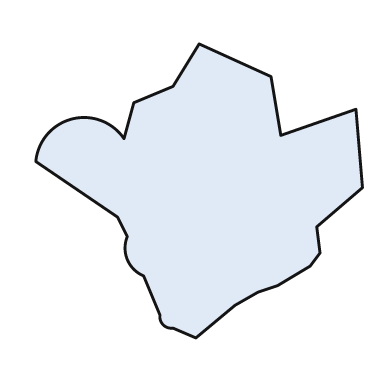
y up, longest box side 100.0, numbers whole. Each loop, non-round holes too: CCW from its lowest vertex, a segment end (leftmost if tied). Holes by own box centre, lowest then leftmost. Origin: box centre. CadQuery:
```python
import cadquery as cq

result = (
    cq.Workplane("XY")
    .moveTo(-1.0, -45.0)
    .lineTo(11.0, -35.0)
    .lineTo(18.0, -31.0)
    .lineTo(24.0, -29.0)
    .lineTo(34.0, -23.0)
    .lineTo(37.0, -19.0)
    .lineTo(36.0, -11.0)
    .lineTo(50.0, 1.0)
    .lineTo(48.0, 25.0)
    .lineTo(25.0, 17.0)
    .lineTo(22.0, 35.0)
    .lineTo(0.0, 45.0)
    .lineTo(-8.0, 32.0)
    .lineTo(-20.0, 27.0)
    .lineTo(-23.0, 16.0)
    .threePointArc((-39.0, 22.0), (-50.0, 9.0))
    .lineTo(-25.0, -8.0)
    .lineTo(-22.0, -14.0)
    .threePointArc((-22.0, -21.0), (-17.0, -26.0))
    .lineTo(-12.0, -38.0)
    .threePointArc((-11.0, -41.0), (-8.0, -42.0))
    .close()
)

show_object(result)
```